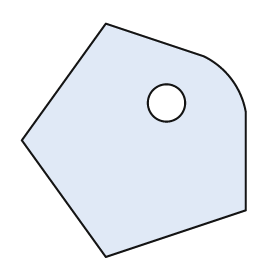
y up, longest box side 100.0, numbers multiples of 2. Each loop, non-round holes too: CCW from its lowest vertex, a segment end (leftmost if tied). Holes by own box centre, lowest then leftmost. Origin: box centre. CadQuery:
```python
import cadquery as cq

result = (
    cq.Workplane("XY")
    .moveTo(-12.0, -50.0)
    .lineTo(48.0, -30.0)
    .lineTo(48.0, 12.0)
    .threePointArc((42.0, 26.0), (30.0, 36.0))
    .lineTo(-12.0, 50.0)
    .lineTo(-48.0, 0.0)
    .close()
    .moveTo(14.0, 16.0)
    .circle(8.0)
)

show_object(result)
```